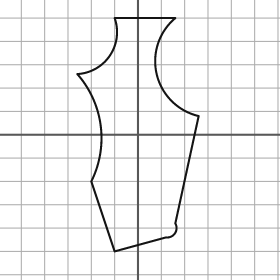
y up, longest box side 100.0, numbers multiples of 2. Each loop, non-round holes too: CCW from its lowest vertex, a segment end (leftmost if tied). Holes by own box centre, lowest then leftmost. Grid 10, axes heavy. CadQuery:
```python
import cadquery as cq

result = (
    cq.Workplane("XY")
    .moveTo(-10.0, -50.0)
    .lineTo(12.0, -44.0)
    .threePointArc((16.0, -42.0), (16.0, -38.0))
    .lineTo(26.0, 8.0)
    .threePointArc((8.0, 26.0), (16.0, 50.0))
    .lineTo(-10.0, 50.0)
    .threePointArc((-12.0, 34.0), (-26.0, 26.0))
    .threePointArc((-16.0, 4.0), (-20.0, -20.0))
    .close()
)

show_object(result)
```